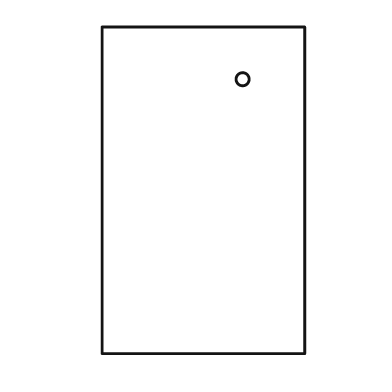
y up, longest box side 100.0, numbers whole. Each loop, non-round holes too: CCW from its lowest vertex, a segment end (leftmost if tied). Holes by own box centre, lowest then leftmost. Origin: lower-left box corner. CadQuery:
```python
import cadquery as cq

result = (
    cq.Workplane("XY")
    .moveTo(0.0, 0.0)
    .lineTo(62.0, 0.0)
    .lineTo(62.0, 100.0)
    .lineTo(0.0, 100.0)
    .close()
    .moveTo(43.0, 84.0)
    .circle(2.0)
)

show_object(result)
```